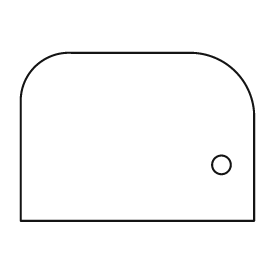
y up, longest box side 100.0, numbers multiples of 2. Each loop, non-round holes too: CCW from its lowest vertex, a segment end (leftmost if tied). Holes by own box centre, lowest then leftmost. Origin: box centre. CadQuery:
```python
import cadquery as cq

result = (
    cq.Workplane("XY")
    .moveTo(-50.0, -36.0)
    .lineTo(50.0, -36.0)
    .lineTo(50.0, 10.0)
    .threePointArc((42.0, 28.0), (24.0, 36.0))
    .lineTo(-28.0, 36.0)
    .threePointArc((-44.0, 30.0), (-50.0, 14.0))
    .close()
    .moveTo(36.0, -12.0)
    .circle(4.0)
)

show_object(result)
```